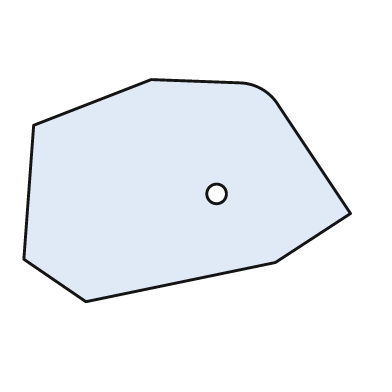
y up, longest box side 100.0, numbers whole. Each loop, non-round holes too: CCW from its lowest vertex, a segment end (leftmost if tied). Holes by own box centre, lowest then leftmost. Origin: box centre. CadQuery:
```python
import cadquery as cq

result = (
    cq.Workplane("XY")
    .moveTo(-31.0, -34.0)
    .lineTo(27.0, -22.0)
    .lineTo(50.0, -7.0)
    .lineTo(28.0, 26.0)
    .threePointArc((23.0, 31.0), (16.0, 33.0))
    .lineTo(-11.0, 34.0)
    .lineTo(-47.0, 20.0)
    .lineTo(-50.0, -21.0)
    .close()
    .moveTo(9.0, -1.0)
    .circle(3.0)
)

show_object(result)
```